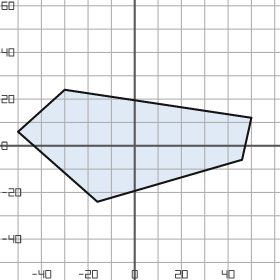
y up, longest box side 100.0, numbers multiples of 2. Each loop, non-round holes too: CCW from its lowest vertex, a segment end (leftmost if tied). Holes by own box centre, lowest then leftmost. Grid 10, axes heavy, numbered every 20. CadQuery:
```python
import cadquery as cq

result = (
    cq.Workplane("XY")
    .moveTo(-16.0, -24.0)
    .lineTo(46.0, -6.0)
    .lineTo(50.0, 12.0)
    .lineTo(-30.0, 24.0)
    .lineTo(-50.0, 6.0)
    .close()
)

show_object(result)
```